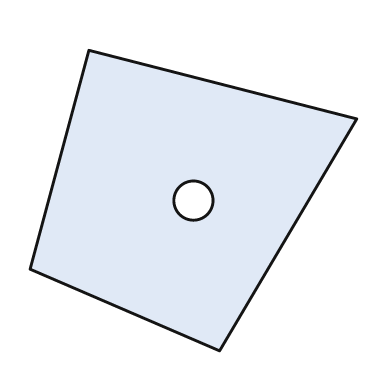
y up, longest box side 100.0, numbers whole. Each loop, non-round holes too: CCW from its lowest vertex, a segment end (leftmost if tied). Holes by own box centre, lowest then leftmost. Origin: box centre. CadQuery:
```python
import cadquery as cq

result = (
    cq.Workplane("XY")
    .moveTo(8.0, -46.0)
    .lineTo(50.0, 25.0)
    .lineTo(-32.0, 46.0)
    .lineTo(-50.0, -21.0)
    .close()
    .moveTo(0.0, 0.0)
    .circle(6.0)
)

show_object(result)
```